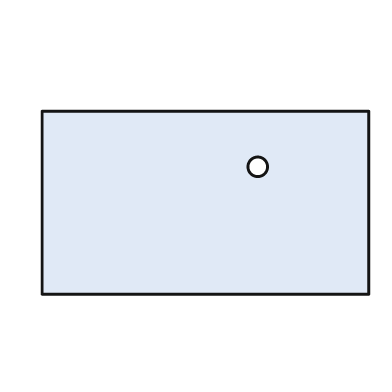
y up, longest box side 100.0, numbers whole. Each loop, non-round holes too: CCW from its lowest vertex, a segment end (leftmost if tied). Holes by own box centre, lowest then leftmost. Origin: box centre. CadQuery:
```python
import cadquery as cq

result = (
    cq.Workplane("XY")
    .moveTo(-50.0, -28.0)
    .lineTo(50.0, -28.0)
    .lineTo(50.0, 28.0)
    .lineTo(-50.0, 28.0)
    .close()
    .moveTo(16.0, 11.0)
    .circle(3.0)
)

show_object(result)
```